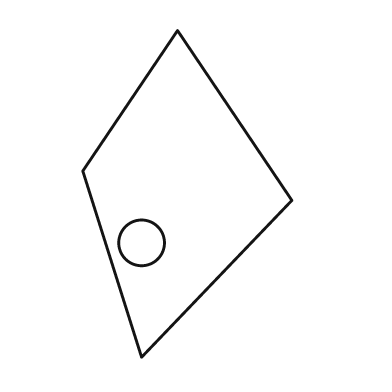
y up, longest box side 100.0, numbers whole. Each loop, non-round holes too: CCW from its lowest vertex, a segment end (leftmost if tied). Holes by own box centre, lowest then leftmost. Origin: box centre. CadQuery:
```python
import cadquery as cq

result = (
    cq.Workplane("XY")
    .moveTo(-14.0, -50.0)
    .lineTo(32.0, -2.0)
    .lineTo(-3.0, 50.0)
    .lineTo(-32.0, 7.0)
    .close()
    .moveTo(-14.0, -15.0)
    .circle(7.0)
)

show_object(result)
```